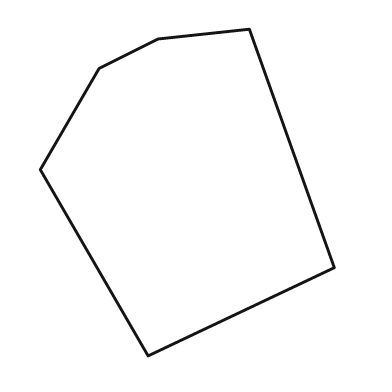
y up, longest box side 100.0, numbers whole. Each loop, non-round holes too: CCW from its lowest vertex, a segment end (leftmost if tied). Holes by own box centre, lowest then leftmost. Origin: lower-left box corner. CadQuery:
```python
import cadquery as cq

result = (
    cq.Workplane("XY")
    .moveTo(33.0, 0.0)
    .lineTo(90.0, 27.0)
    .lineTo(64.0, 100.0)
    .lineTo(36.0, 97.0)
    .lineTo(18.0, 88.0)
    .lineTo(0.0, 57.0)
    .close()
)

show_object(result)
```